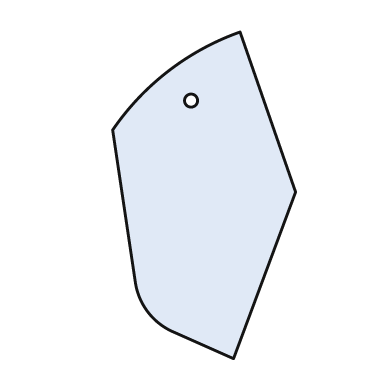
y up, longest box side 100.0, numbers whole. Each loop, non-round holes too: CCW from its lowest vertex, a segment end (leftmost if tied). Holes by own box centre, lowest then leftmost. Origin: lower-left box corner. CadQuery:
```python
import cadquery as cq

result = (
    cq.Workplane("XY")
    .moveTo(37.0, 0.0)
    .lineTo(56.0, 51.0)
    .lineTo(39.0, 100.0)
    .threePointArc((17.0, 88.0), (0.0, 70.0))
    .lineTo(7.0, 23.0)
    .threePointArc((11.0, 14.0), (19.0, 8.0))
    .close()
    .moveTo(24.0, 79.0)
    .circle(2.0)
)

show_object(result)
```